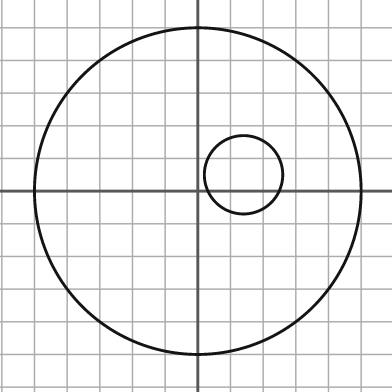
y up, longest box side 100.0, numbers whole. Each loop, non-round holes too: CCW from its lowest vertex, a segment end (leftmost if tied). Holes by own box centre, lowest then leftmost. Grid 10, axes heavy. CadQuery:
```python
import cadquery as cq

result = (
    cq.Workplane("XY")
    .moveTo(0.0, 0.0)
    .circle(50.0)
    .moveTo(14.0, 5.0)
    .circle(12.0)
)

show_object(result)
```